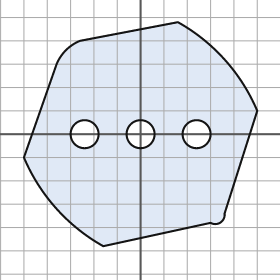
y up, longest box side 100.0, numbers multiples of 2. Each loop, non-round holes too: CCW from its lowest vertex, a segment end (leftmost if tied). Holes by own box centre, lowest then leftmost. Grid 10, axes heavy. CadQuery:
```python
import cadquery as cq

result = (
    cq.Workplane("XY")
    .moveTo(-16.0, -48.0)
    .lineTo(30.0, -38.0)
    .threePointArc((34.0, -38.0), (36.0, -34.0))
    .lineTo(50.0, 10.0)
    .threePointArc((36.0, 32.0), (16.0, 48.0))
    .lineTo(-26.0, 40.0)
    .threePointArc((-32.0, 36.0), (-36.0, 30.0))
    .lineTo(-50.0, -10.0)
    .threePointArc((-36.0, -32.0), (-16.0, -48.0))
    .close()
    .moveTo(-24.0, 0.0)
    .circle(6.0)
    .moveTo(0.0, 0.0)
    .circle(6.0)
    .moveTo(24.0, 0.0)
    .circle(6.0)
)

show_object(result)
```